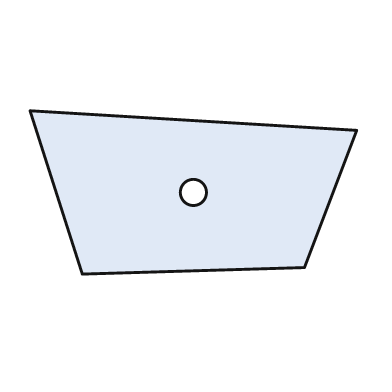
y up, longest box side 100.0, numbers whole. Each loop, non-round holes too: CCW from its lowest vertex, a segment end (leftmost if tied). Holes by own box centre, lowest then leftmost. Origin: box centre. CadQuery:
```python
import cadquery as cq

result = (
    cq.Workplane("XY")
    .moveTo(-34.0, -25.0)
    .lineTo(34.0, -23.0)
    .lineTo(50.0, 19.0)
    .lineTo(-50.0, 25.0)
    .close()
    .moveTo(0.0, 0.0)
    .circle(4.0)
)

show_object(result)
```